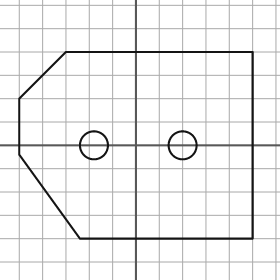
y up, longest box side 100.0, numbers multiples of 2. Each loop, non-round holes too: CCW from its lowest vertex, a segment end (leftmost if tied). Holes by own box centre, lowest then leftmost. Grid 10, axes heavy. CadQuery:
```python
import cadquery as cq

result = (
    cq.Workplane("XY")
    .moveTo(-24.0, -40.0)
    .lineTo(50.0, -40.0)
    .lineTo(50.0, 40.0)
    .lineTo(-30.0, 40.0)
    .lineTo(-50.0, 20.0)
    .lineTo(-50.0, -4.0)
    .close()
    .moveTo(-18.0, 0.0)
    .circle(6.0)
    .moveTo(20.0, 0.0)
    .circle(6.0)
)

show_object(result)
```